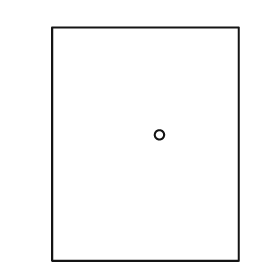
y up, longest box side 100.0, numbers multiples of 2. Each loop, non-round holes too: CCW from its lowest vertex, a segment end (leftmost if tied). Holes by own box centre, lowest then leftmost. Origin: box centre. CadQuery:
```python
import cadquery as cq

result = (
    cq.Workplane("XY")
    .moveTo(-40.0, -50.0)
    .lineTo(40.0, -50.0)
    .lineTo(40.0, 50.0)
    .lineTo(-40.0, 50.0)
    .close()
    .moveTo(6.0, 4.0)
    .circle(2.0)
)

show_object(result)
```